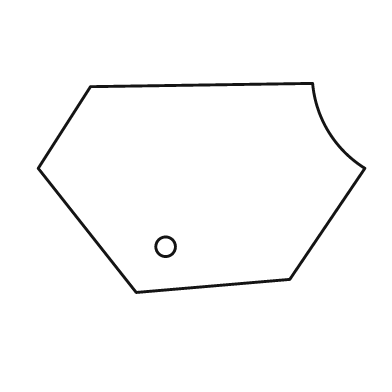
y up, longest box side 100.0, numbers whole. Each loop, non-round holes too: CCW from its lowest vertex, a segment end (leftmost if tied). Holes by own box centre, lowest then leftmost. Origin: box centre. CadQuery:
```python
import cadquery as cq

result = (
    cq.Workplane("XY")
    .moveTo(-20.0, -32.0)
    .lineTo(27.0, -28.0)
    .lineTo(50.0, 6.0)
    .threePointArc((39.0, 17.0), (34.0, 32.0))
    .lineTo(-34.0, 31.0)
    .lineTo(-50.0, 6.0)
    .close()
    .moveTo(-11.0, -18.0)
    .circle(3.0)
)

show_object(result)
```